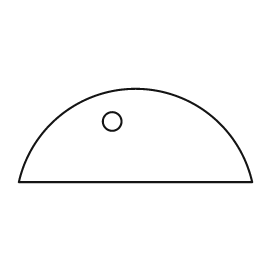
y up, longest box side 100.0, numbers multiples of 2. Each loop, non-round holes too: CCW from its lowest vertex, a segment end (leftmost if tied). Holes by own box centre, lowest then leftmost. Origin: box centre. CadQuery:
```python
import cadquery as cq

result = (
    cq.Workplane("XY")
    .moveTo(-50.0, -20.0)
    .lineTo(50.0, -20.0)
    .threePointArc((0.0, 20.0), (-50.0, -20.0))
    .close()
    .moveTo(-10.0, 6.0)
    .circle(4.0)
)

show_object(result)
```